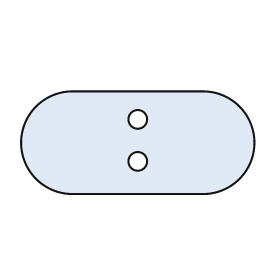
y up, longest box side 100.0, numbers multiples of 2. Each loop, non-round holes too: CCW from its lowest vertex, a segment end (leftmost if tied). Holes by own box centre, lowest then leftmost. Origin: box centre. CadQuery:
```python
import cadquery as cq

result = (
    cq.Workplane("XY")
    .moveTo(-28.0, -22.0)
    .lineTo(28.0, -22.0)
    .threePointArc((50.0, 0.0), (28.0, 22.0))
    .lineTo(-28.0, 22.0)
    .threePointArc((-50.0, 0.0), (-28.0, -22.0))
    .close()
    .moveTo(0.0, -8.0)
    .circle(4.0)
    .moveTo(0.0, 10.0)
    .circle(4.0)
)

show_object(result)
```